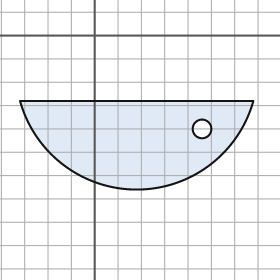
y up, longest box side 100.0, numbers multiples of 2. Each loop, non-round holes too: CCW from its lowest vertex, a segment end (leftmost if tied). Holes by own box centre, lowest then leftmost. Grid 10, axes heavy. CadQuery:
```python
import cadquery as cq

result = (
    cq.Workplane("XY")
    .moveTo(-32.0, -28.0)
    .threePointArc((18.0, -66.0), (68.0, -28.0))
    .close()
    .moveTo(46.0, -40.0)
    .circle(4.0)
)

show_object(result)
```